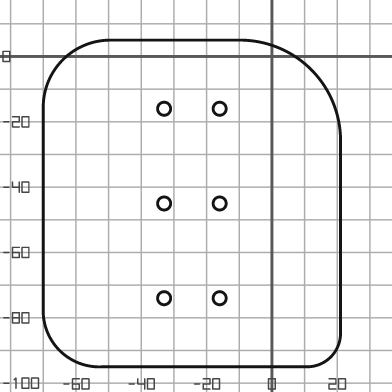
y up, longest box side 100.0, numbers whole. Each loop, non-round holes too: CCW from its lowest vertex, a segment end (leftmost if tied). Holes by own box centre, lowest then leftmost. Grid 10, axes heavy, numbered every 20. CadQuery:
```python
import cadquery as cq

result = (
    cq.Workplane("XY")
    .moveTo(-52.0, -95.0)
    .lineTo(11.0, -95.0)
    .threePointArc((18.0, -92.0), (21.0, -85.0))
    .lineTo(21.0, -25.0)
    .threePointArc((12.0, -4.0), (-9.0, 5.0))
    .lineTo(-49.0, 5.0)
    .threePointArc((-64.0, -1.0), (-70.0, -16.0))
    .lineTo(-70.0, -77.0)
    .threePointArc((-65.0, -90.0), (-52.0, -95.0))
    .close()
    .moveTo(-33.0, -74.0)
    .circle(2.0)
    .moveTo(-16.0, -74.0)
    .circle(2.0)
    .moveTo(-33.0, -45.0)
    .circle(2.0)
    .moveTo(-16.0, -45.0)
    .circle(2.0)
    .moveTo(-33.0, -16.0)
    .circle(2.0)
    .moveTo(-16.0, -16.0)
    .circle(2.0)
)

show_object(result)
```